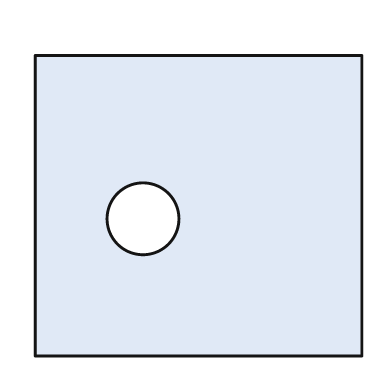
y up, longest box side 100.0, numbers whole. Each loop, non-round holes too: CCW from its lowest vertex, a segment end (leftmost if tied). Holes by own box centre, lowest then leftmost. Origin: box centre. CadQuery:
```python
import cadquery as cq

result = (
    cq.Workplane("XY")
    .moveTo(-50.0, -46.0)
    .lineTo(50.0, -46.0)
    .lineTo(50.0, 46.0)
    .lineTo(-50.0, 46.0)
    .close()
    .moveTo(-17.0, -4.0)
    .circle(11.0)
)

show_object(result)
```